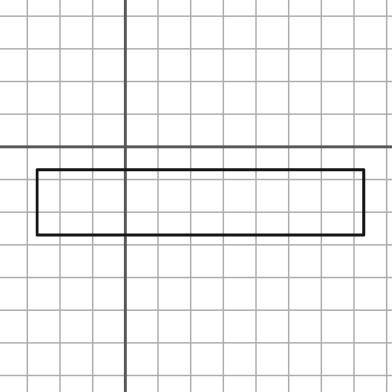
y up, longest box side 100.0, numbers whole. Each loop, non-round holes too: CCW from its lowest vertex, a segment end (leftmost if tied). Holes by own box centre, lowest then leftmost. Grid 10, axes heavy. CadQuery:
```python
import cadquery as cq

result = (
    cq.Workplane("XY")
    .moveTo(-27.0, -27.0)
    .lineTo(73.0, -27.0)
    .lineTo(73.0, -7.0)
    .lineTo(-27.0, -7.0)
    .close()
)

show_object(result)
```